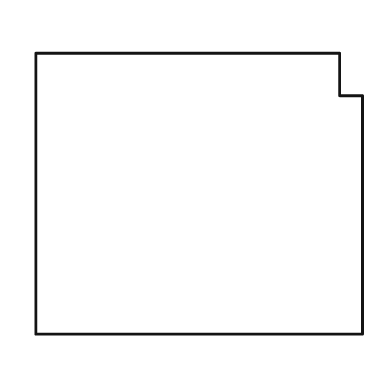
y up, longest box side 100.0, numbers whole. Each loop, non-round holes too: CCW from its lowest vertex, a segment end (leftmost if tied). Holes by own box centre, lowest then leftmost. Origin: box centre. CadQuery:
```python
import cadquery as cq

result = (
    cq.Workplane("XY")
    .moveTo(-50.0, -43.0)
    .lineTo(50.0, -43.0)
    .lineTo(50.0, 30.0)
    .lineTo(43.0, 30.0)
    .lineTo(43.0, 43.0)
    .lineTo(-50.0, 43.0)
    .close()
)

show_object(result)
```